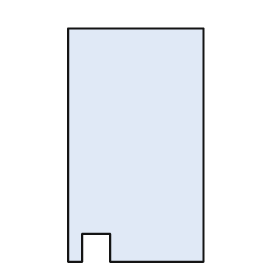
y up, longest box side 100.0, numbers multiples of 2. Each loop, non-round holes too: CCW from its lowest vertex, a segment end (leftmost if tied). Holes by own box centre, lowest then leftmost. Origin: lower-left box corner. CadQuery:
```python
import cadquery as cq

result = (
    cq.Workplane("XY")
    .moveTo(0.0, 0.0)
    .lineTo(6.0, 0.0)
    .lineTo(6.0, 12.0)
    .lineTo(18.0, 12.0)
    .lineTo(18.0, 0.0)
    .lineTo(58.0, 0.0)
    .lineTo(58.0, 100.0)
    .lineTo(0.0, 100.0)
    .close()
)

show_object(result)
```